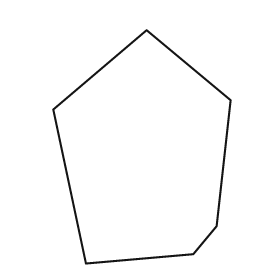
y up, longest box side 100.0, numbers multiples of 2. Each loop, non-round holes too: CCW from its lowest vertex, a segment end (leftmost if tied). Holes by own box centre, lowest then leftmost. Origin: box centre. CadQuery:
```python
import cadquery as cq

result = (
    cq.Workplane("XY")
    .moveTo(-24.0, -50.0)
    .lineTo(22.0, -46.0)
    .lineTo(32.0, -34.0)
    .lineTo(38.0, 20.0)
    .lineTo(2.0, 50.0)
    .lineTo(-38.0, 16.0)
    .close()
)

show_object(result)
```